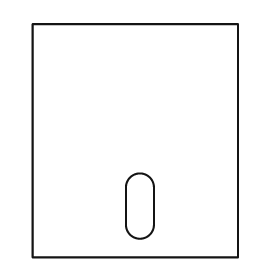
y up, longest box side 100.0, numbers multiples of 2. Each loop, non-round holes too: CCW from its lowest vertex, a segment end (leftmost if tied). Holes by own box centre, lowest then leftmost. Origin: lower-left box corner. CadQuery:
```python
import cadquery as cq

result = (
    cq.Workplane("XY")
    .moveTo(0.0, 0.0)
    .lineTo(88.0, 0.0)
    .lineTo(88.0, 100.0)
    .lineTo(0.0, 100.0)
    .close()
    .moveTo(40.0, 14.0)
    .threePointArc((46.0, 8.0), (52.0, 14.0))
    .lineTo(52.0, 30.0)
    .threePointArc((46.0, 36.0), (40.0, 30.0))
    .close()
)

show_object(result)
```